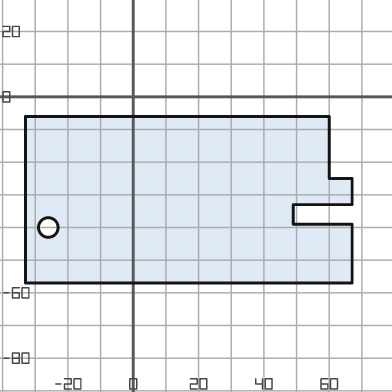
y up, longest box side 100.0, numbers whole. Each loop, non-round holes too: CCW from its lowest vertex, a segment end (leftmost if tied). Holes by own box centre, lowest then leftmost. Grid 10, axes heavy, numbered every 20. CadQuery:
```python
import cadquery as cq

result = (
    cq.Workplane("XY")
    .moveTo(-33.0, -57.0)
    .lineTo(67.0, -57.0)
    .lineTo(67.0, -39.0)
    .lineTo(49.0, -39.0)
    .lineTo(49.0, -33.0)
    .lineTo(67.0, -33.0)
    .lineTo(67.0, -25.0)
    .lineTo(60.0, -25.0)
    .lineTo(60.0, -6.0)
    .lineTo(-33.0, -6.0)
    .close()
    .moveTo(-26.0, -40.0)
    .circle(3.0)
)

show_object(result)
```